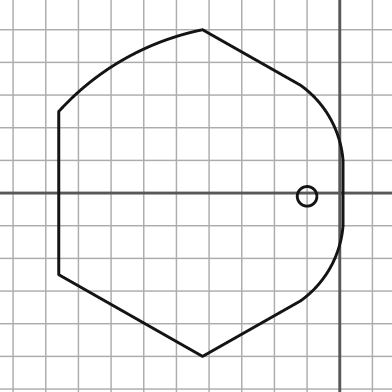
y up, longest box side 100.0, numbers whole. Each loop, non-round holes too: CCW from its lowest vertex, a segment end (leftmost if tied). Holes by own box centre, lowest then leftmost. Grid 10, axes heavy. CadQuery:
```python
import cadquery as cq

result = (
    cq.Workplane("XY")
    .moveTo(-42.0, -50.0)
    .lineTo(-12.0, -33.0)
    .threePointArc((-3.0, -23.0), (1.0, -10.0))
    .lineTo(1.0, 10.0)
    .threePointArc((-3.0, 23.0), (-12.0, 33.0))
    .lineTo(-42.0, 50.0)
    .threePointArc((-66.0, 41.0), (-86.0, 25.0))
    .lineTo(-86.0, -25.0)
    .close()
    .moveTo(-10.0, -1.0)
    .circle(3.0)
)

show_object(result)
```